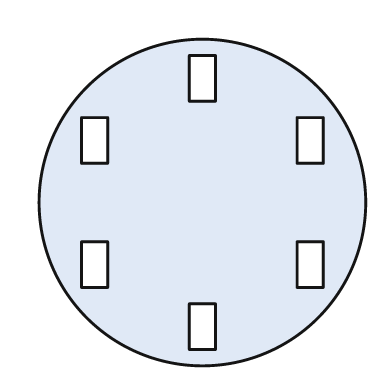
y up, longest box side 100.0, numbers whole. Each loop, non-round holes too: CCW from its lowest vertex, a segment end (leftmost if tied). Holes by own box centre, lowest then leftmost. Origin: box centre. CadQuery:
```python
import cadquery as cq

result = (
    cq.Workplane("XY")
    .moveTo(0.0, 0.0)
    .circle(50.0)
    .moveTo(-4.0, -45.0)
    .lineTo(4.0, -45.0)
    .lineTo(4.0, -31.0)
    .lineTo(-4.0, -31.0)
    .close()
    .moveTo(-37.0, -26.0)
    .lineTo(-29.0, -26.0)
    .lineTo(-29.0, -12.0)
    .lineTo(-37.0, -12.0)
    .close()
    .moveTo(29.0, -26.0)
    .lineTo(37.0, -26.0)
    .lineTo(37.0, -12.0)
    .lineTo(29.0, -12.0)
    .close()
    .moveTo(-37.0, 12.0)
    .lineTo(-29.0, 12.0)
    .lineTo(-29.0, 26.0)
    .lineTo(-37.0, 26.0)
    .close()
    .moveTo(29.0, 12.0)
    .lineTo(37.0, 12.0)
    .lineTo(37.0, 26.0)
    .lineTo(29.0, 26.0)
    .close()
    .moveTo(-4.0, 31.0)
    .lineTo(4.0, 31.0)
    .lineTo(4.0, 45.0)
    .lineTo(-4.0, 45.0)
    .close()
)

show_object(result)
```